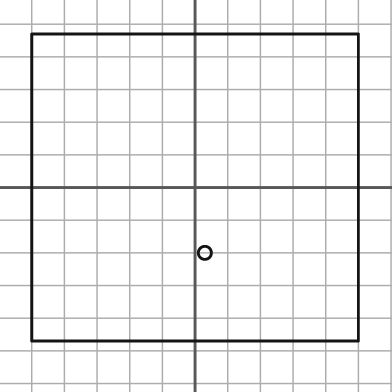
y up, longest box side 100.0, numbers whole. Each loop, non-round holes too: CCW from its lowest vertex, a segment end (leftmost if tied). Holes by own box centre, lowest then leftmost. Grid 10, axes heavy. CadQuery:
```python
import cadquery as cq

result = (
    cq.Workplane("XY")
    .moveTo(-50.0, -47.0)
    .lineTo(50.0, -47.0)
    .lineTo(50.0, 47.0)
    .lineTo(-50.0, 47.0)
    .close()
    .moveTo(3.0, -20.0)
    .circle(2.0)
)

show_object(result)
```